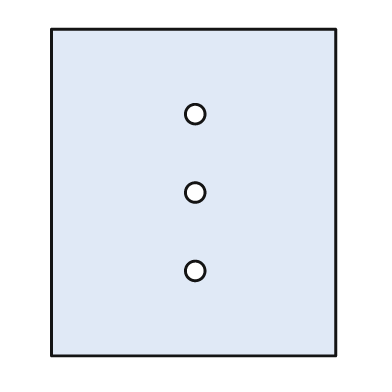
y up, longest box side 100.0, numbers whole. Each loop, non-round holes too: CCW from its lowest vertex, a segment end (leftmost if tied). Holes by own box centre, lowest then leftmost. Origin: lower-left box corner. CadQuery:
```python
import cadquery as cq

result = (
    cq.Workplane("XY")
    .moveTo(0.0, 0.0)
    .lineTo(87.0, 0.0)
    .lineTo(87.0, 100.0)
    .lineTo(0.0, 100.0)
    .close()
    .moveTo(44.0, 26.0)
    .circle(3.0)
    .moveTo(44.0, 50.0)
    .circle(3.0)
    .moveTo(44.0, 74.0)
    .circle(3.0)
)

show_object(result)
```